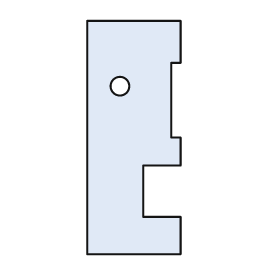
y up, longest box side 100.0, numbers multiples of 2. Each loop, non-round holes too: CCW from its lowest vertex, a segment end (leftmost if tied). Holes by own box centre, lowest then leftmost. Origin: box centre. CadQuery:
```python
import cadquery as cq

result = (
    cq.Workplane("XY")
    .moveTo(-20.0, -50.0)
    .lineTo(20.0, -50.0)
    .lineTo(20.0, -34.0)
    .lineTo(4.0, -34.0)
    .lineTo(4.0, -12.0)
    .lineTo(20.0, -12.0)
    .lineTo(20.0, 0.0)
    .lineTo(16.0, 0.0)
    .lineTo(16.0, 32.0)
    .lineTo(20.0, 32.0)
    .lineTo(20.0, 50.0)
    .lineTo(-20.0, 50.0)
    .close()
    .moveTo(-6.0, 22.0)
    .circle(4.0)
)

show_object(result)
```